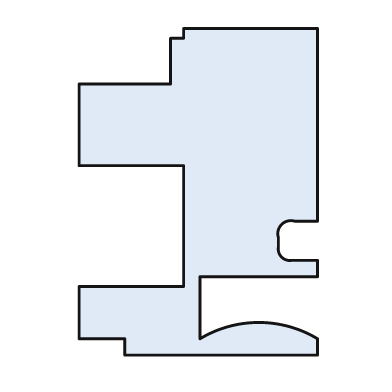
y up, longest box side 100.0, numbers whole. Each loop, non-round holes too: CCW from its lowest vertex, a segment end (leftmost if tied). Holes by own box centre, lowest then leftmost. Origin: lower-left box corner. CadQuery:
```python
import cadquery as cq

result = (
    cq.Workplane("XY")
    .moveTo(14.0, 0.0)
    .lineTo(73.0, 0.0)
    .lineTo(73.0, 5.0)
    .threePointArc((55.0, 10.0), (37.0, 5.0))
    .lineTo(37.0, 24.0)
    .lineTo(73.0, 24.0)
    .lineTo(73.0, 29.0)
    .lineTo(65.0, 29.0)
    .threePointArc((62.0, 30.0), (61.0, 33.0))
    .lineTo(61.0, 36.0)
    .threePointArc((62.0, 40.0), (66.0, 41.0))
    .lineTo(73.0, 41.0)
    .lineTo(73.0, 100.0)
    .lineTo(32.0, 100.0)
    .lineTo(32.0, 97.0)
    .lineTo(28.0, 97.0)
    .lineTo(28.0, 83.0)
    .lineTo(0.0, 83.0)
    .lineTo(0.0, 58.0)
    .lineTo(32.0, 58.0)
    .lineTo(32.0, 21.0)
    .lineTo(0.0, 21.0)
    .lineTo(0.0, 5.0)
    .lineTo(14.0, 5.0)
    .close()
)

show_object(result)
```